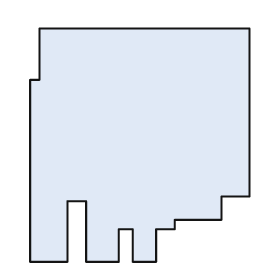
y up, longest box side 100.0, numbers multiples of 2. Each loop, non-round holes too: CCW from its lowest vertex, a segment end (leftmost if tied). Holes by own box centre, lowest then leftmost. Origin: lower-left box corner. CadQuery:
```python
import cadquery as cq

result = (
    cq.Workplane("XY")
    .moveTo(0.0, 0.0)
    .lineTo(16.0, 0.0)
    .lineTo(16.0, 26.0)
    .lineTo(24.0, 26.0)
    .lineTo(24.0, 0.0)
    .lineTo(38.0, 0.0)
    .lineTo(38.0, 14.0)
    .lineTo(44.0, 14.0)
    .lineTo(44.0, 0.0)
    .lineTo(54.0, 0.0)
    .lineTo(54.0, 14.0)
    .lineTo(62.0, 14.0)
    .lineTo(62.0, 18.0)
    .lineTo(82.0, 18.0)
    .lineTo(82.0, 28.0)
    .lineTo(94.0, 28.0)
    .lineTo(94.0, 100.0)
    .lineTo(4.0, 100.0)
    .lineTo(4.0, 78.0)
    .lineTo(0.0, 78.0)
    .close()
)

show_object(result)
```